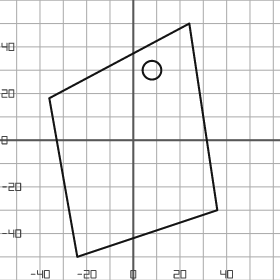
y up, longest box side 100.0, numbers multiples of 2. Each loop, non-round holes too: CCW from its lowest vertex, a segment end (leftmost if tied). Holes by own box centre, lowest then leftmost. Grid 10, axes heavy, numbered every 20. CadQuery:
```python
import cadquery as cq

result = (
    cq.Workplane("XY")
    .moveTo(-24.0, -50.0)
    .lineTo(36.0, -30.0)
    .lineTo(24.0, 50.0)
    .lineTo(-36.0, 18.0)
    .close()
    .moveTo(8.0, 30.0)
    .circle(4.0)
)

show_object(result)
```